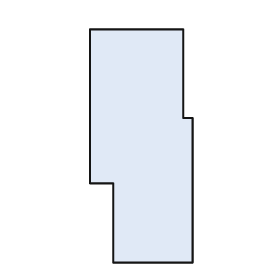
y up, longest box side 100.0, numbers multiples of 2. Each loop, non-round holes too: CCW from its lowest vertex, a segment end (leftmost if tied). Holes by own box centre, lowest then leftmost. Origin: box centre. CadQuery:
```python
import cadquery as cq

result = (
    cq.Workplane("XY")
    .moveTo(-12.0, -50.0)
    .lineTo(22.0, -50.0)
    .lineTo(22.0, 12.0)
    .lineTo(18.0, 12.0)
    .lineTo(18.0, 50.0)
    .lineTo(-22.0, 50.0)
    .lineTo(-22.0, -16.0)
    .lineTo(-12.0, -16.0)
    .close()
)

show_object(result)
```